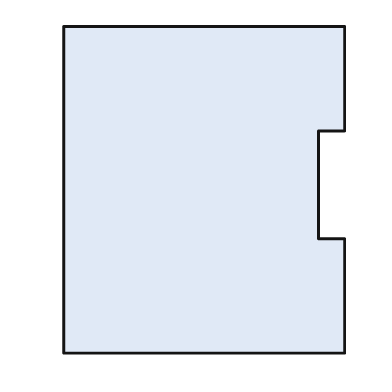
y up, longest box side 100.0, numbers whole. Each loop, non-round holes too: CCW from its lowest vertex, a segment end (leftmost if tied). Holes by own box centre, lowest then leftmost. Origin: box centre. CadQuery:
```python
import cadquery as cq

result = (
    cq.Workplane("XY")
    .moveTo(-43.0, -50.0)
    .lineTo(43.0, -50.0)
    .lineTo(43.0, -15.0)
    .lineTo(35.0, -15.0)
    .lineTo(35.0, 18.0)
    .lineTo(43.0, 18.0)
    .lineTo(43.0, 50.0)
    .lineTo(-43.0, 50.0)
    .close()
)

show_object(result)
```